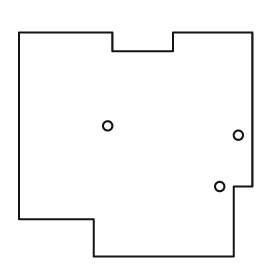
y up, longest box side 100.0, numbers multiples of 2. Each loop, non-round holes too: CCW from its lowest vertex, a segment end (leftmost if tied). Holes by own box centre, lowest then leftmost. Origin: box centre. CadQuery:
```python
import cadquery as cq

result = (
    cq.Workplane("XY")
    .moveTo(-18.0, -48.0)
    .lineTo(42.0, -48.0)
    .lineTo(42.0, -18.0)
    .lineTo(50.0, -18.0)
    .lineTo(50.0, 48.0)
    .lineTo(16.0, 48.0)
    .lineTo(16.0, 40.0)
    .lineTo(-10.0, 40.0)
    .lineTo(-10.0, 48.0)
    .lineTo(-50.0, 48.0)
    .lineTo(-50.0, -32.0)
    .lineTo(-18.0, -32.0)
    .close()
    .moveTo(36.0, -18.0)
    .circle(2.0)
    .moveTo(44.0, 4.0)
    .circle(2.0)
    .moveTo(-12.0, 8.0)
    .circle(2.0)
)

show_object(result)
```